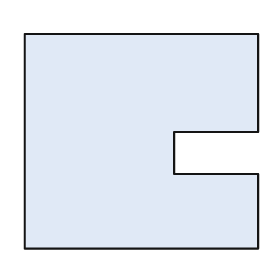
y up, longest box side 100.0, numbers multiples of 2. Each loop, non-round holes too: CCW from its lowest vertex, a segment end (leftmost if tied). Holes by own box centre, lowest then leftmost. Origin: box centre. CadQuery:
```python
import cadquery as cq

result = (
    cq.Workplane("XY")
    .moveTo(-50.0, -46.0)
    .lineTo(50.0, -46.0)
    .lineTo(50.0, -14.0)
    .lineTo(14.0, -14.0)
    .lineTo(14.0, 4.0)
    .lineTo(50.0, 4.0)
    .lineTo(50.0, 46.0)
    .lineTo(-50.0, 46.0)
    .close()
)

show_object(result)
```